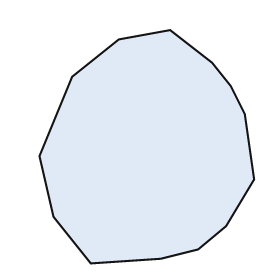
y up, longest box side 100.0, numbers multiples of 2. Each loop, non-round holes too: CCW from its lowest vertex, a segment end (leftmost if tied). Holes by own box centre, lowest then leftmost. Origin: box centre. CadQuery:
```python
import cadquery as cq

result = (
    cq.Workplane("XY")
    .moveTo(-24.0, -50.0)
    .lineTo(6.0, -48.0)
    .lineTo(22.0, -44.0)
    .lineTo(34.0, -34.0)
    .lineTo(46.0, -14.0)
    .lineTo(42.0, 14.0)
    .lineTo(36.0, 26.0)
    .lineTo(28.0, 36.0)
    .lineTo(10.0, 50.0)
    .lineTo(-12.0, 46.0)
    .lineTo(-32.0, 30.0)
    .lineTo(-46.0, -4.0)
    .lineTo(-40.0, -30.0)
    .close()
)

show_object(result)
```